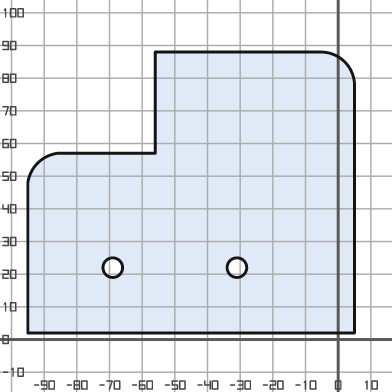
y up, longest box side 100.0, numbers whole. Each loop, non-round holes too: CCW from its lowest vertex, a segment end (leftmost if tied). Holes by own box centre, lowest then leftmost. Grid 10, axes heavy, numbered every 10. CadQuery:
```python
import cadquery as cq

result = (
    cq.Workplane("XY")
    .moveTo(-95.0, 2.0)
    .lineTo(5.0, 2.0)
    .lineTo(5.0, 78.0)
    .threePointArc((2.0, 85.0), (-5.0, 88.0))
    .lineTo(-56.0, 88.0)
    .lineTo(-56.0, 57.0)
    .lineTo(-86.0, 57.0)
    .threePointArc((-92.0, 54.0), (-95.0, 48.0))
    .close()
    .moveTo(-69.0, 22.0)
    .circle(3.0)
    .moveTo(-31.0, 22.0)
    .circle(3.0)
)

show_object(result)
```